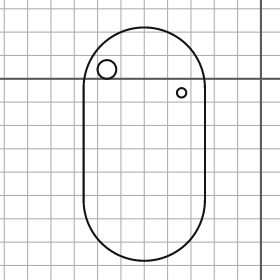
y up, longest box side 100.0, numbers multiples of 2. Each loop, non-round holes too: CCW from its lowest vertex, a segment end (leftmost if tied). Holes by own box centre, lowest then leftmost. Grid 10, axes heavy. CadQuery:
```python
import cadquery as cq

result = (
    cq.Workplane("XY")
    .moveTo(-76.0, -52.0)
    .threePointArc((-50.0, -78.0), (-24.0, -52.0))
    .lineTo(-24.0, -4.0)
    .threePointArc((-50.0, 22.0), (-76.0, -4.0))
    .close()
    .moveTo(-34.0, -6.0)
    .circle(2.0)
    .moveTo(-66.0, 4.0)
    .circle(4.0)
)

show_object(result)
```